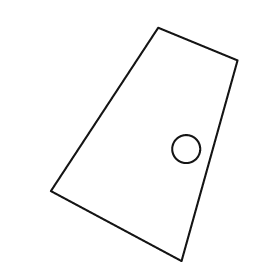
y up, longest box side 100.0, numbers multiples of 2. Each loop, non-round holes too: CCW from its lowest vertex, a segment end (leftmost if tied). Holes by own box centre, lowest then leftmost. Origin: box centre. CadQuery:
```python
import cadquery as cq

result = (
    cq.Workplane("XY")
    .moveTo(16.0, -50.0)
    .lineTo(40.0, 36.0)
    .lineTo(6.0, 50.0)
    .lineTo(-40.0, -20.0)
    .close()
    .moveTo(18.0, -2.0)
    .circle(6.0)
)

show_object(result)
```